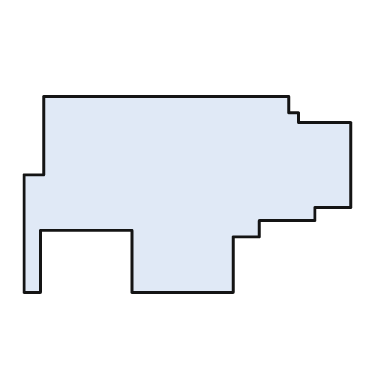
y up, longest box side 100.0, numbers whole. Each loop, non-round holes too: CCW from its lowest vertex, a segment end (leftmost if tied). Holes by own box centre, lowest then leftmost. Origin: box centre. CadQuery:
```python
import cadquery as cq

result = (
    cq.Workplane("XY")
    .moveTo(-50.0, -30.0)
    .lineTo(-45.0, -30.0)
    .lineTo(-45.0, -11.0)
    .lineTo(-17.0, -11.0)
    .lineTo(-17.0, -30.0)
    .lineTo(14.0, -30.0)
    .lineTo(14.0, -13.0)
    .lineTo(22.0, -13.0)
    .lineTo(22.0, -8.0)
    .lineTo(39.0, -8.0)
    .lineTo(39.0, -4.0)
    .lineTo(50.0, -4.0)
    .lineTo(50.0, 22.0)
    .lineTo(34.0, 22.0)
    .lineTo(34.0, 25.0)
    .lineTo(31.0, 25.0)
    .lineTo(31.0, 30.0)
    .lineTo(-44.0, 30.0)
    .lineTo(-44.0, 6.0)
    .lineTo(-50.0, 6.0)
    .close()
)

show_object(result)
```